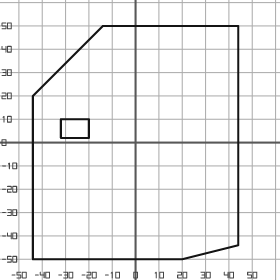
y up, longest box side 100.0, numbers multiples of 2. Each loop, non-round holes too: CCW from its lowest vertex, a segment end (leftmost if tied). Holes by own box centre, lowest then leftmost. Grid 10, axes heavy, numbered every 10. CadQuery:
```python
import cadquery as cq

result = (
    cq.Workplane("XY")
    .moveTo(-44.0, -50.0)
    .lineTo(20.0, -50.0)
    .lineTo(44.0, -44.0)
    .lineTo(44.0, 50.0)
    .lineTo(-14.0, 50.0)
    .lineTo(-44.0, 20.0)
    .close()
    .moveTo(-32.0, 2.0)
    .lineTo(-20.0, 2.0)
    .lineTo(-20.0, 10.0)
    .lineTo(-32.0, 10.0)
    .close()
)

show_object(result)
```